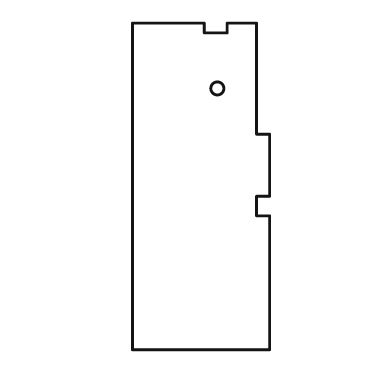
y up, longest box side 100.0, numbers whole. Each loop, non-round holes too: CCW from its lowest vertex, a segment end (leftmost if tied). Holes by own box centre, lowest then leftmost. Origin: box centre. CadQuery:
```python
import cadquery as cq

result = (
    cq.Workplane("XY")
    .moveTo(-21.0, -50.0)
    .lineTo(21.0, -50.0)
    .lineTo(21.0, -9.0)
    .lineTo(17.0, -9.0)
    .lineTo(17.0, -3.0)
    .lineTo(21.0, -3.0)
    .lineTo(21.0, 16.0)
    .lineTo(17.0, 16.0)
    .lineTo(17.0, 50.0)
    .lineTo(8.0, 50.0)
    .lineTo(8.0, 47.0)
    .lineTo(1.0, 47.0)
    .lineTo(1.0, 50.0)
    .lineTo(-21.0, 50.0)
    .close()
    .moveTo(5.0, 30.0)
    .circle(2.0)
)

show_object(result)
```